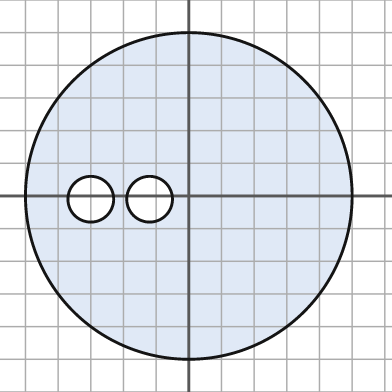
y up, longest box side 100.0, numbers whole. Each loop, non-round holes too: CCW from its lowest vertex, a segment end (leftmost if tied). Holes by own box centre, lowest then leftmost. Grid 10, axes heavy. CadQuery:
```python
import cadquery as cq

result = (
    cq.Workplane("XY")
    .moveTo(0.0, 0.0)
    .circle(50.0)
    .moveTo(-30.0, -1.0)
    .circle(7.0)
    .moveTo(-12.0, -1.0)
    .circle(7.0)
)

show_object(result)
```